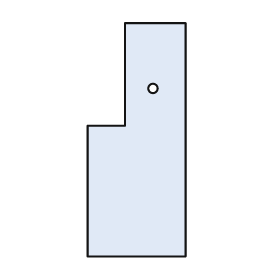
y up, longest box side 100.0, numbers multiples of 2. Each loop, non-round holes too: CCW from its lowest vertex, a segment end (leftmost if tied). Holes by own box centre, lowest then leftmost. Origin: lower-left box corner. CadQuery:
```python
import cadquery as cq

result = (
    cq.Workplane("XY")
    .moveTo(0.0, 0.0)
    .lineTo(42.0, 0.0)
    .lineTo(42.0, 100.0)
    .lineTo(16.0, 100.0)
    .lineTo(16.0, 56.0)
    .lineTo(0.0, 56.0)
    .close()
    .moveTo(28.0, 72.0)
    .circle(2.0)
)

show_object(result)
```